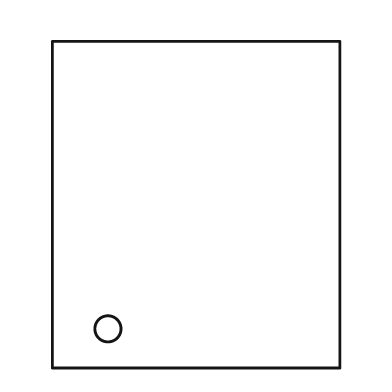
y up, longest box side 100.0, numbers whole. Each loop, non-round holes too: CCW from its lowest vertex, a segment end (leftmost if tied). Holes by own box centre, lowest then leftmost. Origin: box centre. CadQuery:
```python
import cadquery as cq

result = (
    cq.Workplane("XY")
    .moveTo(-44.0, -50.0)
    .lineTo(44.0, -50.0)
    .lineTo(44.0, 50.0)
    .lineTo(-44.0, 50.0)
    .close()
    .moveTo(-27.0, -38.0)
    .circle(4.0)
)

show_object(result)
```